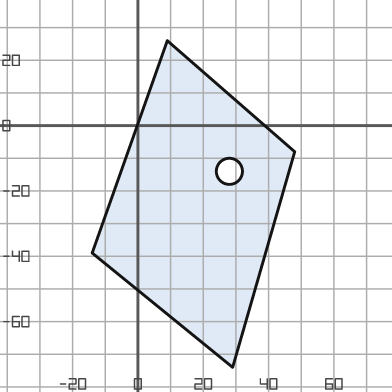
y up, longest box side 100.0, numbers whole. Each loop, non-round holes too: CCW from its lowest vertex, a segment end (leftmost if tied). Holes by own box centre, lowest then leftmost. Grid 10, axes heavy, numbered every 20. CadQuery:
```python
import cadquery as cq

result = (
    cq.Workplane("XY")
    .moveTo(29.0, -74.0)
    .lineTo(48.0, -8.0)
    .lineTo(9.0, 26.0)
    .lineTo(-14.0, -39.0)
    .close()
    .moveTo(28.0, -14.0)
    .circle(4.0)
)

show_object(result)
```